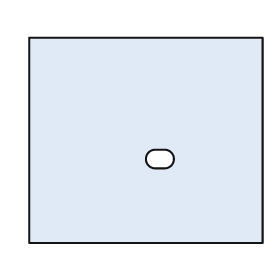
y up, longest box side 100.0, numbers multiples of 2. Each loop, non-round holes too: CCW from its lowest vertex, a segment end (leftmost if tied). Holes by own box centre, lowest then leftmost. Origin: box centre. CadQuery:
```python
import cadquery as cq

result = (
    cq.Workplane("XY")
    .moveTo(-50.0, -44.0)
    .lineTo(50.0, -44.0)
    .lineTo(50.0, 44.0)
    .lineTo(-50.0, 44.0)
    .close()
    .moveTo(4.0, -12.0)
    .lineTo(8.0, -12.0)
    .threePointArc((12.0, -8.0), (8.0, -4.0))
    .lineTo(4.0, -4.0)
    .threePointArc((0.0, -8.0), (4.0, -12.0))
    .close()
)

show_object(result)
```